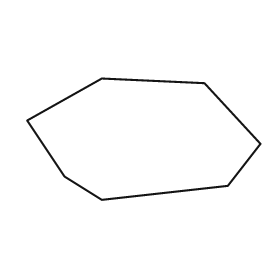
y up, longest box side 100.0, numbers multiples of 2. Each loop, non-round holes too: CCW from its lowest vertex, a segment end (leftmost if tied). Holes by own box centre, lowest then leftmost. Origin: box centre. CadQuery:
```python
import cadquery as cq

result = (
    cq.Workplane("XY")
    .moveTo(-18.0, -26.0)
    .lineTo(36.0, -20.0)
    .lineTo(50.0, -2.0)
    .lineTo(26.0, 24.0)
    .lineTo(-18.0, 26.0)
    .lineTo(-50.0, 8.0)
    .lineTo(-34.0, -16.0)
    .close()
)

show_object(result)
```